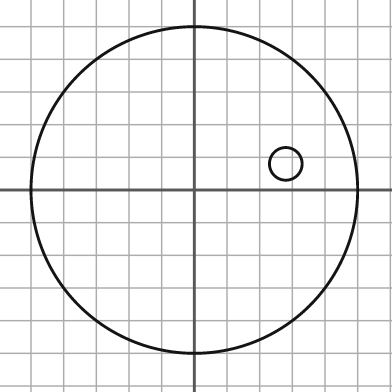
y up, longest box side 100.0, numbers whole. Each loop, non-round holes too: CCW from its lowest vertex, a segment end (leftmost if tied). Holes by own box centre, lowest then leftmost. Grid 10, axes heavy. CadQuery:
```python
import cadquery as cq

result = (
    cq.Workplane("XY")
    .moveTo(0.0, 0.0)
    .circle(50.0)
    .moveTo(28.0, 8.0)
    .circle(5.0)
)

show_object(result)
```